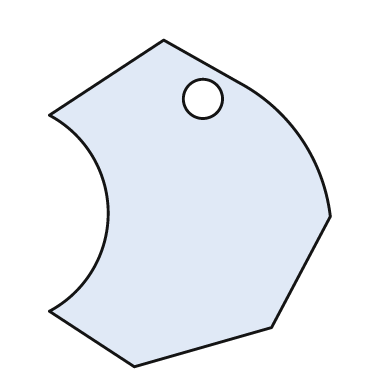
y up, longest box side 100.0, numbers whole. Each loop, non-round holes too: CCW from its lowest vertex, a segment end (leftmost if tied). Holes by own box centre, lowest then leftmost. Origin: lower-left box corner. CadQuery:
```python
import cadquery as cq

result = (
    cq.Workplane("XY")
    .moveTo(26.0, 0.0)
    .lineTo(68.0, 12.0)
    .lineTo(86.0, 46.0)
    .threePointArc((77.0, 70.0), (58.0, 87.0))
    .lineTo(35.0, 100.0)
    .lineTo(0.0, 77.0)
    .threePointArc((18.0, 47.0), (0.0, 17.0))
    .close()
    .moveTo(47.0, 82.0)
    .circle(6.0)
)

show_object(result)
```